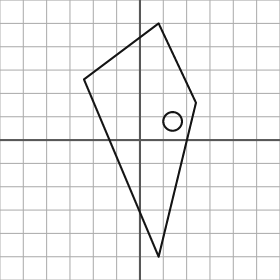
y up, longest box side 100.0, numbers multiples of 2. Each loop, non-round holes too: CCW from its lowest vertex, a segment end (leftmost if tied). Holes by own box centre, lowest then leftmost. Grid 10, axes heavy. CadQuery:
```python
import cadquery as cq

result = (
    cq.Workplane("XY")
    .moveTo(8.0, -50.0)
    .lineTo(24.0, 16.0)
    .lineTo(8.0, 50.0)
    .lineTo(-24.0, 26.0)
    .close()
    .moveTo(14.0, 8.0)
    .circle(4.0)
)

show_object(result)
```